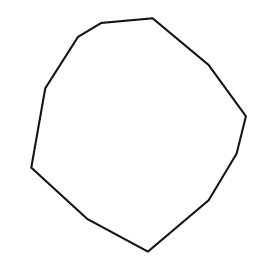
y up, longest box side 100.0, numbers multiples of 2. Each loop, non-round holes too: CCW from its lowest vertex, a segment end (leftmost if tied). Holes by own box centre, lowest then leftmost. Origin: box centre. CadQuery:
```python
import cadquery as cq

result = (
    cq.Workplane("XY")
    .moveTo(4.0, -50.0)
    .lineTo(30.0, -28.0)
    .lineTo(42.0, -8.0)
    .lineTo(46.0, 8.0)
    .lineTo(30.0, 30.0)
    .lineTo(6.0, 50.0)
    .lineTo(-16.0, 48.0)
    .lineTo(-26.0, 42.0)
    .lineTo(-40.0, 20.0)
    .lineTo(-46.0, -14.0)
    .lineTo(-22.0, -36.0)
    .close()
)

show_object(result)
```